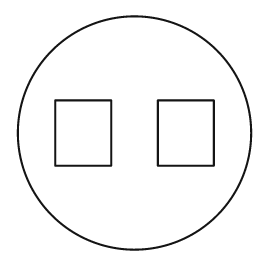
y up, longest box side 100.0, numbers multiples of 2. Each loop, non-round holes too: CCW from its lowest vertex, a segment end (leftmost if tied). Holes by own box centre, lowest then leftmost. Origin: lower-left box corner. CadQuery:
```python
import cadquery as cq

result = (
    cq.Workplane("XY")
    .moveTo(50.0, 50.0)
    .circle(50.0)
    .moveTo(16.0, 36.0)
    .lineTo(40.0, 36.0)
    .lineTo(40.0, 64.0)
    .lineTo(16.0, 64.0)
    .close()
    .moveTo(60.0, 36.0)
    .lineTo(84.0, 36.0)
    .lineTo(84.0, 64.0)
    .lineTo(60.0, 64.0)
    .close()
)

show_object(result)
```